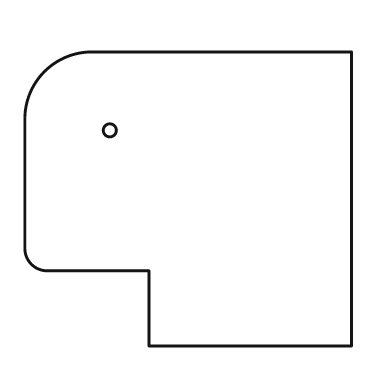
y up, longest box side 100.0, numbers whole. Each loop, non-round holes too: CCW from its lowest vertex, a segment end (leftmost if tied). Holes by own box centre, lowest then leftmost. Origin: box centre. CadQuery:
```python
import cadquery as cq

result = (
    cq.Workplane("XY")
    .moveTo(-12.0, -45.0)
    .lineTo(50.0, -45.0)
    .lineTo(50.0, 45.0)
    .lineTo(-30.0, 45.0)
    .threePointArc((-44.0, 39.0), (-50.0, 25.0))
    .lineTo(-50.0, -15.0)
    .threePointArc((-48.0, -20.0), (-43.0, -22.0))
    .lineTo(-12.0, -22.0)
    .close()
    .moveTo(-24.0, 21.0)
    .circle(2.0)
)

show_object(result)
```